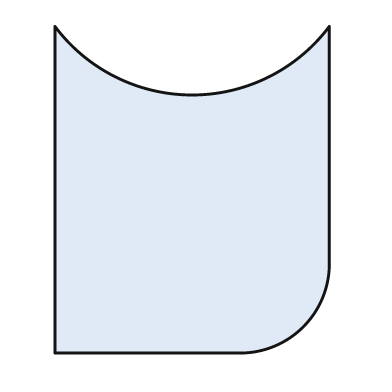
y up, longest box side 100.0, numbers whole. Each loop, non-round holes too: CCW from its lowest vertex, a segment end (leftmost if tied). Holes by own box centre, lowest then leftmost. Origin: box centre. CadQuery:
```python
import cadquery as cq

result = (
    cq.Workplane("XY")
    .moveTo(-42.0, -50.0)
    .lineTo(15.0, -50.0)
    .threePointArc((34.0, -42.0), (42.0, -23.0))
    .lineTo(42.0, 50.0)
    .threePointArc((0.0, 29.0), (-42.0, 50.0))
    .close()
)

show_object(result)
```